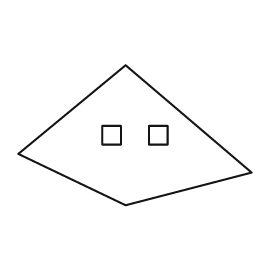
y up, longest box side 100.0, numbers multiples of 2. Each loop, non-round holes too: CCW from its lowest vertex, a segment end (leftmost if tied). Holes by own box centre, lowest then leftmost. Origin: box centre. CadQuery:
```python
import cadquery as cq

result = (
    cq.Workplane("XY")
    .moveTo(-4.0, -30.0)
    .lineTo(50.0, -16.0)
    .lineTo(-4.0, 30.0)
    .lineTo(-50.0, -8.0)
    .close()
    .moveTo(-14.0, -4.0)
    .lineTo(-6.0, -4.0)
    .lineTo(-6.0, 4.0)
    .lineTo(-14.0, 4.0)
    .close()
    .moveTo(6.0, -4.0)
    .lineTo(14.0, -4.0)
    .lineTo(14.0, 4.0)
    .lineTo(6.0, 4.0)
    .close()
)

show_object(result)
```